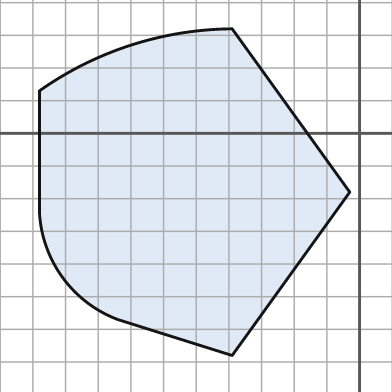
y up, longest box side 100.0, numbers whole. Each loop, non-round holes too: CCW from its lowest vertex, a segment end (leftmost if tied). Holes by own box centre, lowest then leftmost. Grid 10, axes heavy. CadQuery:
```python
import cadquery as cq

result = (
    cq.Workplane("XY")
    .moveTo(-39.0, -68.0)
    .lineTo(-3.0, -18.0)
    .lineTo(-39.0, 32.0)
    .threePointArc((-70.0, 27.0), (-98.0, 13.0))
    .lineTo(-98.0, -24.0)
    .threePointArc((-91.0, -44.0), (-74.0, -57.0))
    .close()
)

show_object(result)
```